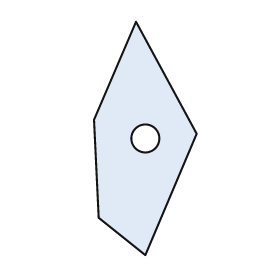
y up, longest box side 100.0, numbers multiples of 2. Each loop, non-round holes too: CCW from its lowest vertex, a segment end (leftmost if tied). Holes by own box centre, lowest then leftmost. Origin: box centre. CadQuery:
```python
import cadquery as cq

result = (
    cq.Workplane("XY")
    .moveTo(0.0, -50.0)
    .lineTo(22.0, 2.0)
    .lineTo(-4.0, 50.0)
    .lineTo(-22.0, 8.0)
    .lineTo(-20.0, -34.0)
    .close()
    .moveTo(0.0, 0.0)
    .circle(6.0)
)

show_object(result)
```